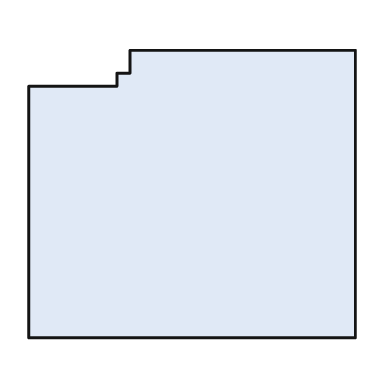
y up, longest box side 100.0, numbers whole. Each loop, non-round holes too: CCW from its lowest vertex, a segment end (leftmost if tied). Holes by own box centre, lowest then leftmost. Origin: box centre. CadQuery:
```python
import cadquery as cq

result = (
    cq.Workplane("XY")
    .moveTo(-50.0, -44.0)
    .lineTo(50.0, -44.0)
    .lineTo(50.0, 44.0)
    .lineTo(-19.0, 44.0)
    .lineTo(-19.0, 37.0)
    .lineTo(-23.0, 37.0)
    .lineTo(-23.0, 33.0)
    .lineTo(-50.0, 33.0)
    .close()
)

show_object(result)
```